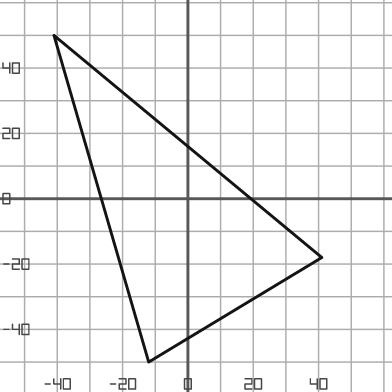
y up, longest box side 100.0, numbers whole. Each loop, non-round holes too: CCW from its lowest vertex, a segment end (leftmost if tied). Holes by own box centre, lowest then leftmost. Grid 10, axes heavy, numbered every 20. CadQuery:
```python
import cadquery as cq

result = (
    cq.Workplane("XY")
    .moveTo(-12.0, -50.0)
    .lineTo(41.0, -18.0)
    .lineTo(-41.0, 50.0)
    .close()
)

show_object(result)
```